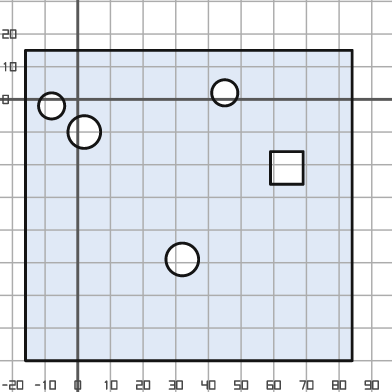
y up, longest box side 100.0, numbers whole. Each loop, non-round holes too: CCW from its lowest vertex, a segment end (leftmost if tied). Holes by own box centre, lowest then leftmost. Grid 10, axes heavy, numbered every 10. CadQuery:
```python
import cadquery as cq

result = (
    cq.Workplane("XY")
    .moveTo(-16.0, -80.0)
    .lineTo(84.0, -80.0)
    .lineTo(84.0, 15.0)
    .lineTo(-16.0, 15.0)
    .close()
    .moveTo(32.0, -49.0)
    .circle(5.0)
    .moveTo(59.0, -26.0)
    .lineTo(69.0, -26.0)
    .lineTo(69.0, -16.0)
    .lineTo(59.0, -16.0)
    .close()
    .moveTo(2.0, -10.0)
    .circle(5.0)
    .moveTo(-8.0, -2.0)
    .circle(4.0)
    .moveTo(45.0, 2.0)
    .circle(4.0)
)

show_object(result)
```